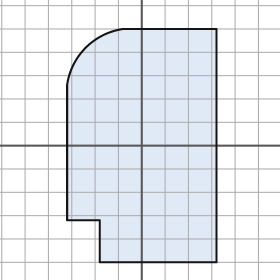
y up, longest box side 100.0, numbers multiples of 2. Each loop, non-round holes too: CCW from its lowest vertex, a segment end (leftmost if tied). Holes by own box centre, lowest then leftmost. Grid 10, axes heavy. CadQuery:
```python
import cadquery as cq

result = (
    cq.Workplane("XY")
    .moveTo(-18.0, -50.0)
    .lineTo(32.0, -50.0)
    .lineTo(32.0, 50.0)
    .lineTo(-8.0, 50.0)
    .threePointArc((-24.0, 42.0), (-32.0, 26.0))
    .lineTo(-32.0, -32.0)
    .lineTo(-18.0, -32.0)
    .close()
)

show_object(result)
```